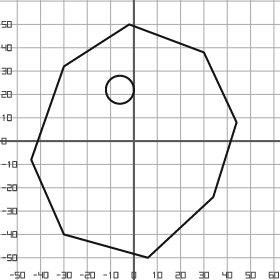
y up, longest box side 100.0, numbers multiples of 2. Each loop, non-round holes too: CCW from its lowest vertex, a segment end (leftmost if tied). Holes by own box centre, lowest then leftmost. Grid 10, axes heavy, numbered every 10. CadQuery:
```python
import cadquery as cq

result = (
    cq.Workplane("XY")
    .moveTo(6.0, -50.0)
    .lineTo(34.0, -24.0)
    .lineTo(44.0, 8.0)
    .lineTo(30.0, 38.0)
    .lineTo(-2.0, 50.0)
    .lineTo(-30.0, 32.0)
    .lineTo(-44.0, -8.0)
    .lineTo(-30.0, -40.0)
    .close()
    .moveTo(-6.0, 22.0)
    .circle(6.0)
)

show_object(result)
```